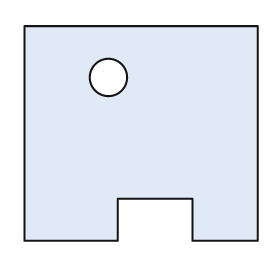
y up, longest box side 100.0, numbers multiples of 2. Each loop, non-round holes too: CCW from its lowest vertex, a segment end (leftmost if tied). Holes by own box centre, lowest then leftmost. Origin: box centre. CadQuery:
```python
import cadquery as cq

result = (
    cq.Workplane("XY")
    .moveTo(-50.0, -46.0)
    .lineTo(-10.0, -46.0)
    .lineTo(-10.0, -28.0)
    .lineTo(22.0, -28.0)
    .lineTo(22.0, -46.0)
    .lineTo(50.0, -46.0)
    .lineTo(50.0, 46.0)
    .lineTo(-50.0, 46.0)
    .close()
    .moveTo(-14.0, 24.0)
    .circle(8.0)
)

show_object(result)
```